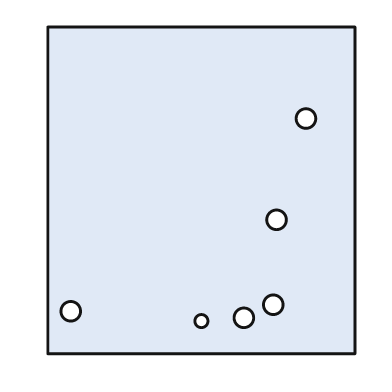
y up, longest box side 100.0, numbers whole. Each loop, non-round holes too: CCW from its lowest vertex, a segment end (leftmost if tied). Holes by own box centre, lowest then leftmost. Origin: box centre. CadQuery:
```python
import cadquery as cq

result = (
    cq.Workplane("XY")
    .moveTo(-47.0, -50.0)
    .lineTo(47.0, -50.0)
    .lineTo(47.0, 50.0)
    .lineTo(-47.0, 50.0)
    .close()
    .moveTo(0.0, -40.0)
    .circle(2.0)
    .moveTo(13.0, -39.0)
    .circle(3.0)
    .moveTo(-40.0, -37.0)
    .circle(3.0)
    .moveTo(22.0, -35.0)
    .circle(3.0)
    .moveTo(23.0, -9.0)
    .circle(3.0)
    .moveTo(32.0, 22.0)
    .circle(3.0)
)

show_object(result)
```